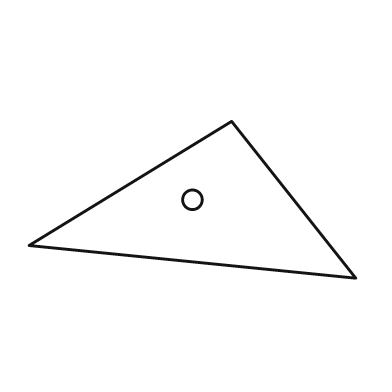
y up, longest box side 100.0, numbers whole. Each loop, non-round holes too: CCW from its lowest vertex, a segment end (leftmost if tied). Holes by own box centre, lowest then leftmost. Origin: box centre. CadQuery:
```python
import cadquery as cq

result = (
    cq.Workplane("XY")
    .moveTo(50.0, -24.0)
    .lineTo(12.0, 24.0)
    .lineTo(-50.0, -14.0)
    .close()
    .moveTo(0.0, 0.0)
    .circle(3.0)
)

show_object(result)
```